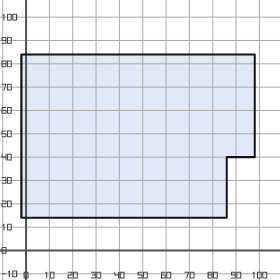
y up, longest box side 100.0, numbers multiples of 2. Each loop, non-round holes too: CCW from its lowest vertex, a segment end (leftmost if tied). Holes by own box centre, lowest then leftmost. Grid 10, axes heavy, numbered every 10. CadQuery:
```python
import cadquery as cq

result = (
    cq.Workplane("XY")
    .moveTo(-2.0, 14.0)
    .lineTo(86.0, 14.0)
    .lineTo(86.0, 40.0)
    .lineTo(98.0, 40.0)
    .lineTo(98.0, 84.0)
    .lineTo(-2.0, 84.0)
    .close()
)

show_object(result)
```